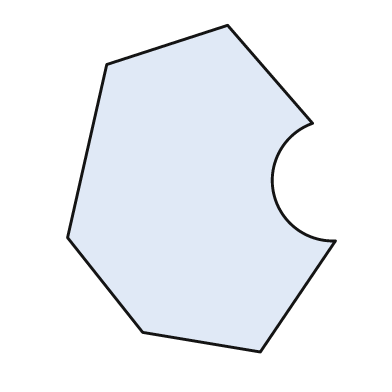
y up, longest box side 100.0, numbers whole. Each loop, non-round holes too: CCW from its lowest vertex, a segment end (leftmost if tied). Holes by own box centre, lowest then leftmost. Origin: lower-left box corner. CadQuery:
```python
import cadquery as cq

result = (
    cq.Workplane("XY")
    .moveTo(59.0, 0.0)
    .lineTo(82.0, 34.0)
    .threePointArc((63.0, 49.0), (75.0, 70.0))
    .lineTo(49.0, 100.0)
    .lineTo(12.0, 88.0)
    .lineTo(0.0, 35.0)
    .lineTo(23.0, 6.0)
    .close()
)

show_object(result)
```